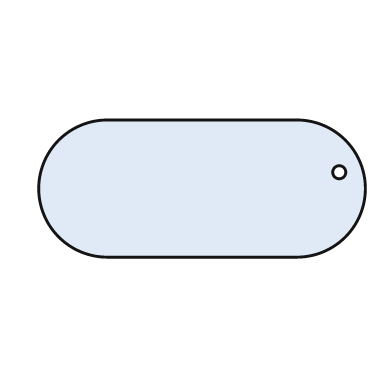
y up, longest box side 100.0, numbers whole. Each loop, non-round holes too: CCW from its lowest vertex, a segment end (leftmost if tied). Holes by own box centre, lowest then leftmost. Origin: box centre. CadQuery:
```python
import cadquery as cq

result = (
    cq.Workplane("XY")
    .moveTo(-29.0, -21.0)
    .lineTo(29.0, -21.0)
    .threePointArc((50.0, 0.0), (29.0, 21.0))
    .lineTo(-29.0, 21.0)
    .threePointArc((-50.0, 0.0), (-29.0, -21.0))
    .close()
    .moveTo(42.0, 5.0)
    .circle(2.0)
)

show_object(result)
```